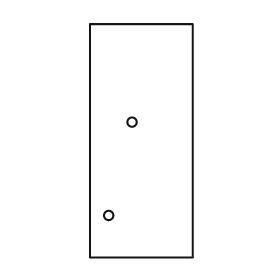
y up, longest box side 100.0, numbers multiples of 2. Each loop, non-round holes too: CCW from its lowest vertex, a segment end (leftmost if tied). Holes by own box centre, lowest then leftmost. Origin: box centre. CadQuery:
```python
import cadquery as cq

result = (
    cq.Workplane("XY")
    .moveTo(-22.0, -50.0)
    .lineTo(22.0, -50.0)
    .lineTo(22.0, 50.0)
    .lineTo(-22.0, 50.0)
    .close()
    .moveTo(-14.0, -32.0)
    .circle(2.0)
    .moveTo(-4.0, 8.0)
    .circle(2.0)
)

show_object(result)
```